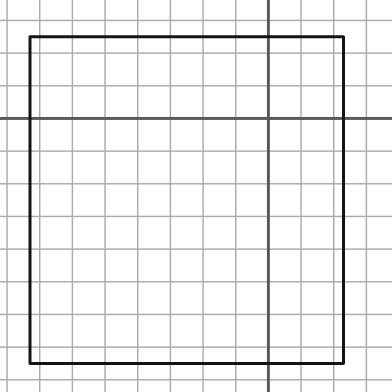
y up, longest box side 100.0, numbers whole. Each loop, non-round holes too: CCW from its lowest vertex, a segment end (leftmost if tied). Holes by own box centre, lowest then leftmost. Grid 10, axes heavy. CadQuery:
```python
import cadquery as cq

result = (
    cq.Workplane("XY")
    .moveTo(-73.0, -75.0)
    .lineTo(23.0, -75.0)
    .lineTo(23.0, 25.0)
    .lineTo(-73.0, 25.0)
    .close()
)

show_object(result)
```